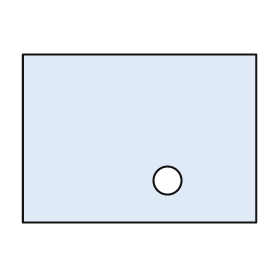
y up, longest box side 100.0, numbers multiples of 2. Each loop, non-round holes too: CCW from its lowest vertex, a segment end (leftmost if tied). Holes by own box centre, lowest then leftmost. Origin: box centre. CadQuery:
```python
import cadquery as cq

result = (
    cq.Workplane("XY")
    .moveTo(-50.0, -36.0)
    .lineTo(50.0, -36.0)
    .lineTo(50.0, 36.0)
    .lineTo(-50.0, 36.0)
    .close()
    .moveTo(12.0, -18.0)
    .circle(6.0)
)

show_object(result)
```